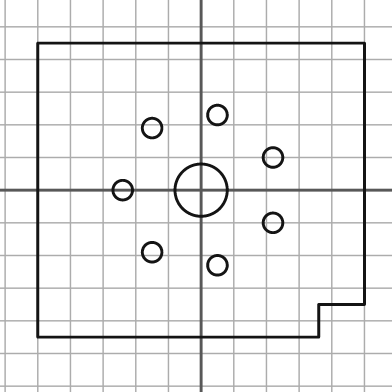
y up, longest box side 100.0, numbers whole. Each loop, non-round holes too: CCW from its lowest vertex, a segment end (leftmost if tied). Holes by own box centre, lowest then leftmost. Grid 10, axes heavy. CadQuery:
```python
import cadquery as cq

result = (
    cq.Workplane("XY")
    .moveTo(-50.0, -45.0)
    .lineTo(36.0, -45.0)
    .lineTo(36.0, -35.0)
    .lineTo(50.0, -35.0)
    .lineTo(50.0, 45.0)
    .lineTo(-50.0, 45.0)
    .close()
    .moveTo(5.0, -23.0)
    .circle(3.0)
    .moveTo(-15.0, -19.0)
    .circle(3.0)
    .moveTo(22.0, -10.0)
    .circle(3.0)
    .moveTo(-24.0, 0.0)
    .circle(3.0)
    .moveTo(0.0, 0.0)
    .circle(8.0)
    .moveTo(22.0, 10.0)
    .circle(3.0)
    .moveTo(-15.0, 19.0)
    .circle(3.0)
    .moveTo(5.0, 23.0)
    .circle(3.0)
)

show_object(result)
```